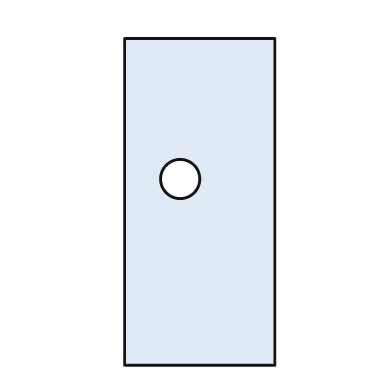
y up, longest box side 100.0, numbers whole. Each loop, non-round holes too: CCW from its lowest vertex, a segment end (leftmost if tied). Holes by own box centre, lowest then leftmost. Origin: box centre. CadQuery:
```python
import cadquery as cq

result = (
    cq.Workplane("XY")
    .moveTo(-23.0, -50.0)
    .lineTo(23.0, -50.0)
    .lineTo(23.0, 50.0)
    .lineTo(-23.0, 50.0)
    .close()
    .moveTo(-6.0, 7.0)
    .circle(6.0)
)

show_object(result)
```